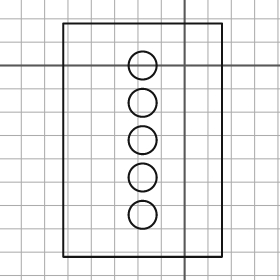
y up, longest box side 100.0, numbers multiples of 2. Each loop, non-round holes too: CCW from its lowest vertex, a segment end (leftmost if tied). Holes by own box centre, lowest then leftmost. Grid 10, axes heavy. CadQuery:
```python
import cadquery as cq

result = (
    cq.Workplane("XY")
    .moveTo(-52.0, -82.0)
    .lineTo(16.0, -82.0)
    .lineTo(16.0, 18.0)
    .lineTo(-52.0, 18.0)
    .close()
    .moveTo(-18.0, -64.0)
    .circle(6.0)
    .moveTo(-18.0, -48.0)
    .circle(6.0)
    .moveTo(-18.0, -32.0)
    .circle(6.0)
    .moveTo(-18.0, -16.0)
    .circle(6.0)
    .moveTo(-18.0, 0.0)
    .circle(6.0)
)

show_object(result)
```